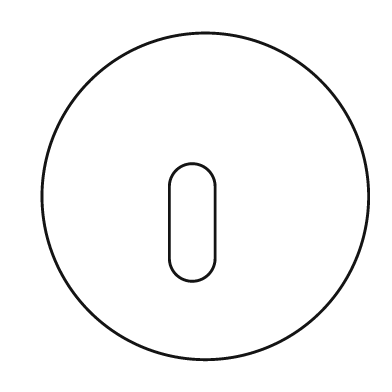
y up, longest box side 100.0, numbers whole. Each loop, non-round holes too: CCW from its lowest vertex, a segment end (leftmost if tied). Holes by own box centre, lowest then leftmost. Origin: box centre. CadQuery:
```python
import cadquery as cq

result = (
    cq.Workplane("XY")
    .moveTo(0.0, 0.0)
    .circle(50.0)
    .moveTo(-11.0, -19.0)
    .threePointArc((-4.0, -26.0), (3.0, -19.0))
    .lineTo(3.0, 3.0)
    .threePointArc((-4.0, 10.0), (-11.0, 3.0))
    .close()
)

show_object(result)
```